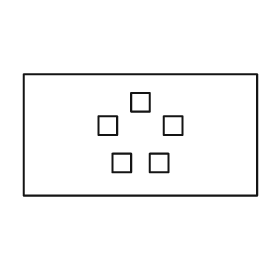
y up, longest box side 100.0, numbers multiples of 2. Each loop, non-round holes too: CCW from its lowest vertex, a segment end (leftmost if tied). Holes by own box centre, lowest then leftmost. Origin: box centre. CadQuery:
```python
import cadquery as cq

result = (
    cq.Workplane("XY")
    .moveTo(-50.0, -26.0)
    .lineTo(50.0, -26.0)
    .lineTo(50.0, 26.0)
    .lineTo(-50.0, 26.0)
    .close()
    .moveTo(-12.0, -16.0)
    .lineTo(-4.0, -16.0)
    .lineTo(-4.0, -8.0)
    .lineTo(-12.0, -8.0)
    .close()
    .moveTo(4.0, -16.0)
    .lineTo(12.0, -16.0)
    .lineTo(12.0, -8.0)
    .lineTo(4.0, -8.0)
    .close()
    .moveTo(-18.0, 0.0)
    .lineTo(-10.0, 0.0)
    .lineTo(-10.0, 8.0)
    .lineTo(-18.0, 8.0)
    .close()
    .moveTo(10.0, 0.0)
    .lineTo(18.0, 0.0)
    .lineTo(18.0, 8.0)
    .lineTo(10.0, 8.0)
    .close()
    .moveTo(-4.0, 10.0)
    .lineTo(4.0, 10.0)
    .lineTo(4.0, 18.0)
    .lineTo(-4.0, 18.0)
    .close()
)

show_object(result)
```